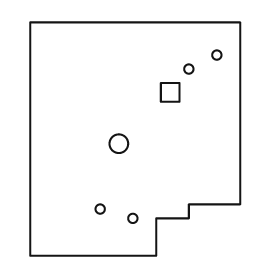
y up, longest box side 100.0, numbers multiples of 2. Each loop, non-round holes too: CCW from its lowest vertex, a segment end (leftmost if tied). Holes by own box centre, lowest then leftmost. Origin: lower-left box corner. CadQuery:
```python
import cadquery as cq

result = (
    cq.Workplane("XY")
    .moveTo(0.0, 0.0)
    .lineTo(54.0, 0.0)
    .lineTo(54.0, 16.0)
    .lineTo(68.0, 16.0)
    .lineTo(68.0, 22.0)
    .lineTo(90.0, 22.0)
    .lineTo(90.0, 100.0)
    .lineTo(0.0, 100.0)
    .close()
    .moveTo(44.0, 16.0)
    .circle(2.0)
    .moveTo(30.0, 20.0)
    .circle(2.0)
    .moveTo(38.0, 48.0)
    .circle(4.0)
    .moveTo(56.0, 66.0)
    .lineTo(64.0, 66.0)
    .lineTo(64.0, 74.0)
    .lineTo(56.0, 74.0)
    .close()
    .moveTo(68.0, 80.0)
    .circle(2.0)
    .moveTo(80.0, 86.0)
    .circle(2.0)
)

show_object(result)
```